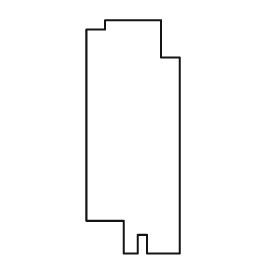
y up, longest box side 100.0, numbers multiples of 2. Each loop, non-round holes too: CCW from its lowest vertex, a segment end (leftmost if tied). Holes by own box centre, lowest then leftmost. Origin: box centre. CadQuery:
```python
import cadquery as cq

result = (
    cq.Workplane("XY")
    .moveTo(-4.0, -50.0)
    .lineTo(2.0, -50.0)
    .lineTo(2.0, -42.0)
    .lineTo(6.0, -42.0)
    .lineTo(6.0, -50.0)
    .lineTo(20.0, -50.0)
    .lineTo(20.0, 34.0)
    .lineTo(12.0, 34.0)
    .lineTo(12.0, 50.0)
    .lineTo(-12.0, 50.0)
    .lineTo(-12.0, 46.0)
    .lineTo(-20.0, 46.0)
    .lineTo(-20.0, -36.0)
    .lineTo(-4.0, -36.0)
    .close()
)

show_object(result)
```